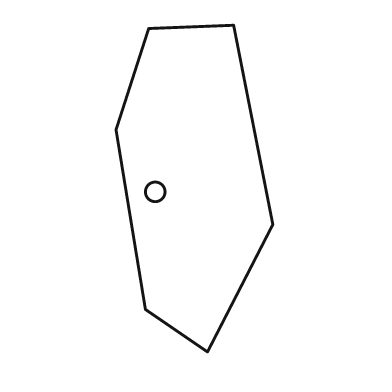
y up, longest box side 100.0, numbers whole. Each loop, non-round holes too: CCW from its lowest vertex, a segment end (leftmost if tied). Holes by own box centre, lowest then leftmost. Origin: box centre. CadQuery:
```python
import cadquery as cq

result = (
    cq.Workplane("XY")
    .moveTo(4.0, -50.0)
    .lineTo(24.0, -11.0)
    .lineTo(12.0, 50.0)
    .lineTo(-14.0, 49.0)
    .lineTo(-24.0, 18.0)
    .lineTo(-15.0, -37.0)
    .close()
    .moveTo(-12.0, -1.0)
    .circle(3.0)
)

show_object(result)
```